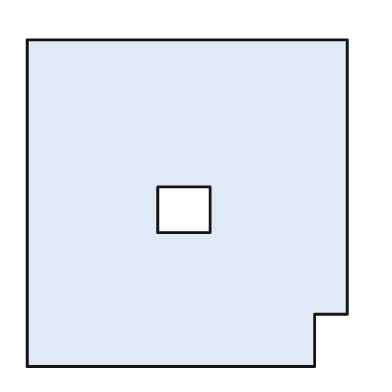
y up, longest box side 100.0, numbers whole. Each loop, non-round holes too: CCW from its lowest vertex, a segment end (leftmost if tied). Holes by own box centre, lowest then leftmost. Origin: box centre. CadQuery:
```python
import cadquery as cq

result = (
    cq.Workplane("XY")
    .moveTo(-49.0, -50.0)
    .lineTo(39.0, -50.0)
    .lineTo(39.0, -34.0)
    .lineTo(49.0, -34.0)
    .lineTo(49.0, 50.0)
    .lineTo(-49.0, 50.0)
    .close()
    .moveTo(-9.0, -9.0)
    .lineTo(7.0, -9.0)
    .lineTo(7.0, 5.0)
    .lineTo(-9.0, 5.0)
    .close()
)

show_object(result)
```